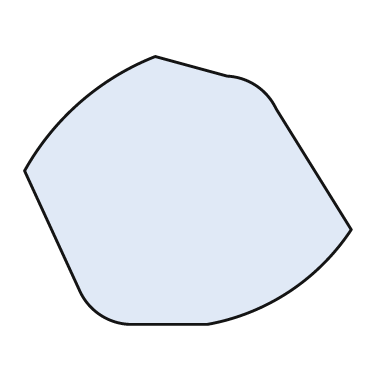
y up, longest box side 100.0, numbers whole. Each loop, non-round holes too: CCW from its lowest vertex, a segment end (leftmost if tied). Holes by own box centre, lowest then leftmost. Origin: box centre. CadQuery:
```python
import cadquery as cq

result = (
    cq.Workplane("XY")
    .moveTo(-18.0, -41.0)
    .lineTo(6.0, -41.0)
    .threePointArc((31.0, -31.0), (50.0, -12.0))
    .lineTo(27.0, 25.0)
    .threePointArc((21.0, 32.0), (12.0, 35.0))
    .lineTo(-10.0, 41.0)
    .threePointArc((-33.0, 27.0), (-50.0, 6.0))
    .lineTo(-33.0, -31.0)
    .threePointArc((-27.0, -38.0), (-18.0, -41.0))
    .close()
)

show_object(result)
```